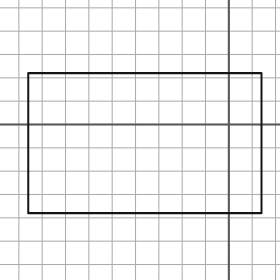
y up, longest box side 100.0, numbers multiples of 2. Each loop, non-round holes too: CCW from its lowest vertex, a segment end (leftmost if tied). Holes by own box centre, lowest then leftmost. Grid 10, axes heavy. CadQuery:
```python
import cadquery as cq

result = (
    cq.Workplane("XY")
    .moveTo(-86.0, -38.0)
    .lineTo(14.0, -38.0)
    .lineTo(14.0, 22.0)
    .lineTo(-86.0, 22.0)
    .close()
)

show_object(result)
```